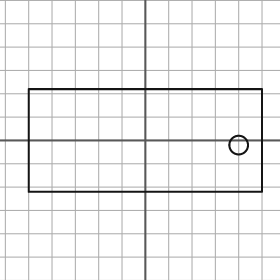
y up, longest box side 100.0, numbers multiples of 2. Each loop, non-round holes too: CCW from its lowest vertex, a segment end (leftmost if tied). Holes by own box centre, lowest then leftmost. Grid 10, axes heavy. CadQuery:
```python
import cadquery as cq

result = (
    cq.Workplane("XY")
    .moveTo(-50.0, -22.0)
    .lineTo(50.0, -22.0)
    .lineTo(50.0, 22.0)
    .lineTo(-50.0, 22.0)
    .close()
    .moveTo(40.0, -2.0)
    .circle(4.0)
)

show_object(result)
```